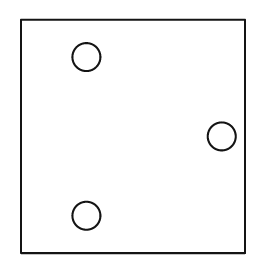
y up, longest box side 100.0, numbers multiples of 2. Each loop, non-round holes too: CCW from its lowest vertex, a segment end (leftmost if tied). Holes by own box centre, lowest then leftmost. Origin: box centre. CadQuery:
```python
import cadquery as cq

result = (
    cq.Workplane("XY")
    .moveTo(-48.0, -50.0)
    .lineTo(48.0, -50.0)
    .lineTo(48.0, 50.0)
    .lineTo(-48.0, 50.0)
    .close()
    .moveTo(-20.0, -34.0)
    .circle(6.0)
    .moveTo(38.0, 0.0)
    .circle(6.0)
    .moveTo(-20.0, 34.0)
    .circle(6.0)
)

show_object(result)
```